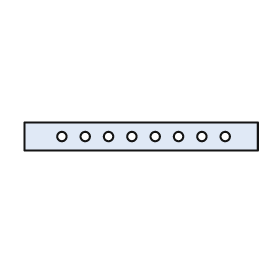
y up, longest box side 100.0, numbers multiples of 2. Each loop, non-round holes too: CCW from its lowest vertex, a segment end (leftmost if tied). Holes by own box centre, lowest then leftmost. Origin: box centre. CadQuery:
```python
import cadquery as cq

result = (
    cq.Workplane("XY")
    .moveTo(-50.0, -6.0)
    .lineTo(50.0, -6.0)
    .lineTo(50.0, 6.0)
    .lineTo(-50.0, 6.0)
    .close()
    .moveTo(-34.0, 0.0)
    .circle(2.0)
    .moveTo(-24.0, 0.0)
    .circle(2.0)
    .moveTo(-14.0, 0.0)
    .circle(2.0)
    .moveTo(-4.0, 0.0)
    .circle(2.0)
    .moveTo(6.0, 0.0)
    .circle(2.0)
    .moveTo(16.0, 0.0)
    .circle(2.0)
    .moveTo(26.0, 0.0)
    .circle(2.0)
    .moveTo(36.0, 0.0)
    .circle(2.0)
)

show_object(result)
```